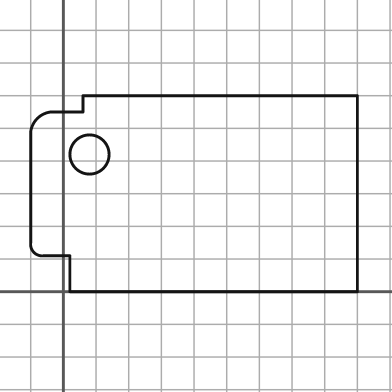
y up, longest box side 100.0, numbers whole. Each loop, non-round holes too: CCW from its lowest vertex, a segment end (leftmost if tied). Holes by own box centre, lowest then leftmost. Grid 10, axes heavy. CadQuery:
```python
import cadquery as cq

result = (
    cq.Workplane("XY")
    .moveTo(2.0, 0.0)
    .lineTo(90.0, 0.0)
    .lineTo(90.0, 60.0)
    .lineTo(6.0, 60.0)
    .lineTo(6.0, 55.0)
    .lineTo(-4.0, 55.0)
    .threePointArc((-8.0, 53.0), (-10.0, 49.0))
    .lineTo(-10.0, 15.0)
    .threePointArc((-9.0, 12.0), (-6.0, 11.0))
    .lineTo(2.0, 11.0)
    .close()
    .moveTo(8.0, 42.0)
    .circle(6.0)
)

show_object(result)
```